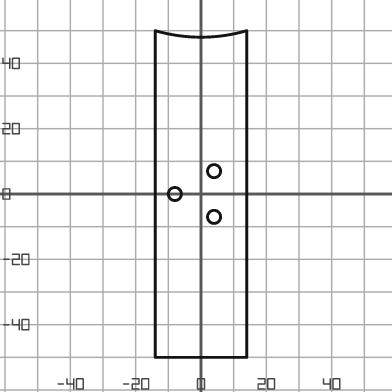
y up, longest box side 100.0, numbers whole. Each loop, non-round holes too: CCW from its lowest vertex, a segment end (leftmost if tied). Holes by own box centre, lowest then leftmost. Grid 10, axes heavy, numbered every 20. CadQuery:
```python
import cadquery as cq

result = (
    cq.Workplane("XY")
    .moveTo(-14.0, -50.0)
    .lineTo(14.0, -50.0)
    .lineTo(14.0, 50.0)
    .threePointArc((0.0, 48.0), (-14.0, 50.0))
    .close()
    .moveTo(4.0, -7.0)
    .circle(2.0)
    .moveTo(-8.0, 0.0)
    .circle(2.0)
    .moveTo(4.0, 7.0)
    .circle(2.0)
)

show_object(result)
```